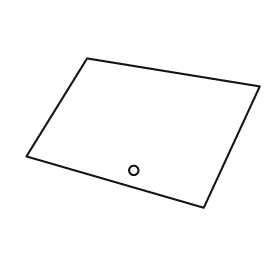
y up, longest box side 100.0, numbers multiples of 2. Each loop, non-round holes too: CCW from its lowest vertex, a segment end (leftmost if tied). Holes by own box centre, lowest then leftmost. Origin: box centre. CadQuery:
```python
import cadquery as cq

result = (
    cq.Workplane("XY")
    .moveTo(26.0, -32.0)
    .lineTo(50.0, 20.0)
    .lineTo(-24.0, 32.0)
    .lineTo(-50.0, -10.0)
    .close()
    .moveTo(-4.0, -16.0)
    .circle(2.0)
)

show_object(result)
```